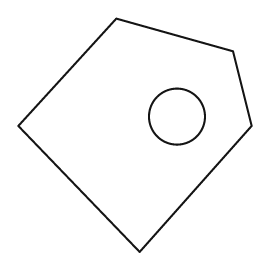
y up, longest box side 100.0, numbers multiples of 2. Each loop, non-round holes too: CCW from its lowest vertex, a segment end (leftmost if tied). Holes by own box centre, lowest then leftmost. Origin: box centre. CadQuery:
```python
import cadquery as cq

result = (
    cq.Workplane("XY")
    .moveTo(2.0, -50.0)
    .lineTo(50.0, 4.0)
    .lineTo(42.0, 36.0)
    .lineTo(-8.0, 50.0)
    .lineTo(-50.0, 4.0)
    .close()
    .moveTo(18.0, 8.0)
    .circle(12.0)
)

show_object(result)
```